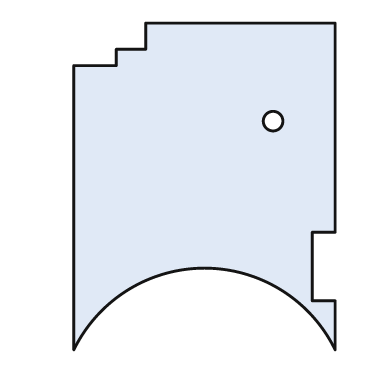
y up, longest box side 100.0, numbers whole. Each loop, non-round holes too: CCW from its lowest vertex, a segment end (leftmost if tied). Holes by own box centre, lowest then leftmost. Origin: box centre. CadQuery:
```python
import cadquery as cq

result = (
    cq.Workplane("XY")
    .moveTo(-40.0, -50.0)
    .threePointArc((0.0, -25.0), (40.0, -50.0))
    .lineTo(40.0, -35.0)
    .lineTo(33.0, -35.0)
    .lineTo(33.0, -14.0)
    .lineTo(40.0, -14.0)
    .lineTo(40.0, 50.0)
    .lineTo(-18.0, 50.0)
    .lineTo(-18.0, 42.0)
    .lineTo(-27.0, 42.0)
    .lineTo(-27.0, 37.0)
    .lineTo(-40.0, 37.0)
    .close()
    .moveTo(21.0, 20.0)
    .circle(3.0)
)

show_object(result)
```